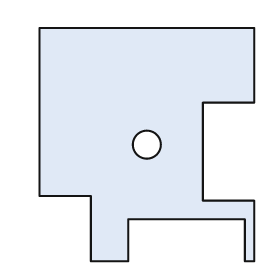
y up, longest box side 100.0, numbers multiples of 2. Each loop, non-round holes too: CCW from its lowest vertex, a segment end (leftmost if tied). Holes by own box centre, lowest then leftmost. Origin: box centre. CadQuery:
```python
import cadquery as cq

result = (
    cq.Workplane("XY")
    .moveTo(-24.0, -50.0)
    .lineTo(-8.0, -50.0)
    .lineTo(-8.0, -32.0)
    .lineTo(42.0, -32.0)
    .lineTo(42.0, -50.0)
    .lineTo(46.0, -50.0)
    .lineTo(46.0, -24.0)
    .lineTo(24.0, -24.0)
    .lineTo(24.0, 18.0)
    .lineTo(46.0, 18.0)
    .lineTo(46.0, 50.0)
    .lineTo(-46.0, 50.0)
    .lineTo(-46.0, -22.0)
    .lineTo(-24.0, -22.0)
    .close()
    .moveTo(0.0, 0.0)
    .circle(6.0)
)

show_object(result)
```